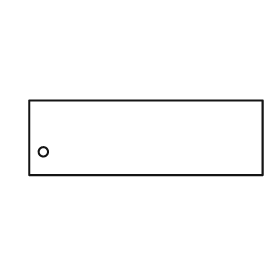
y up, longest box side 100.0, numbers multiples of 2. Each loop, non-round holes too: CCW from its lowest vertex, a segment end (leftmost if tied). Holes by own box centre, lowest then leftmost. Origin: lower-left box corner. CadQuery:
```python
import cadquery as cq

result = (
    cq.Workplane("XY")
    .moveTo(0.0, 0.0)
    .lineTo(100.0, 0.0)
    .lineTo(100.0, 32.0)
    .lineTo(0.0, 32.0)
    .close()
    .moveTo(6.0, 10.0)
    .circle(2.0)
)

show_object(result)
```